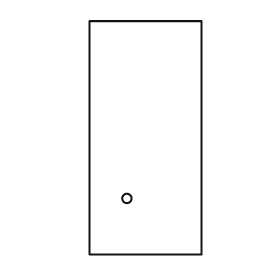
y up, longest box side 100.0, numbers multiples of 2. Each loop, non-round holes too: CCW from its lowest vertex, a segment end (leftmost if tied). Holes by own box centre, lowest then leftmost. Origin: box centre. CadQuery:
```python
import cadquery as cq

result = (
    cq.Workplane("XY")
    .moveTo(-24.0, -50.0)
    .lineTo(24.0, -50.0)
    .lineTo(24.0, 50.0)
    .lineTo(-24.0, 50.0)
    .close()
    .moveTo(-8.0, -26.0)
    .circle(2.0)
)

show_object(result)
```